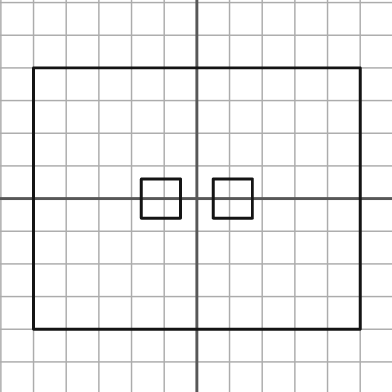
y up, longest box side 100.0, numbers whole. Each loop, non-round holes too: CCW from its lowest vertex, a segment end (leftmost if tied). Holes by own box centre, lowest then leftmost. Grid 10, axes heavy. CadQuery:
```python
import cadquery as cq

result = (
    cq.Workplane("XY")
    .moveTo(-50.0, -40.0)
    .lineTo(50.0, -40.0)
    .lineTo(50.0, 40.0)
    .lineTo(-50.0, 40.0)
    .close()
    .moveTo(-17.0, -6.0)
    .lineTo(-5.0, -6.0)
    .lineTo(-5.0, 6.0)
    .lineTo(-17.0, 6.0)
    .close()
    .moveTo(5.0, -6.0)
    .lineTo(17.0, -6.0)
    .lineTo(17.0, 6.0)
    .lineTo(5.0, 6.0)
    .close()
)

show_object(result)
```